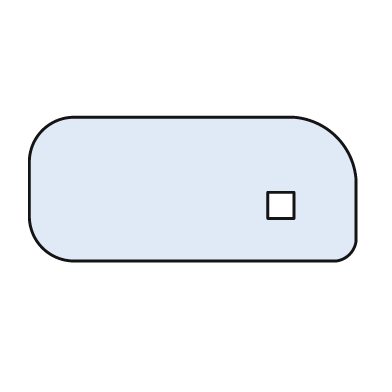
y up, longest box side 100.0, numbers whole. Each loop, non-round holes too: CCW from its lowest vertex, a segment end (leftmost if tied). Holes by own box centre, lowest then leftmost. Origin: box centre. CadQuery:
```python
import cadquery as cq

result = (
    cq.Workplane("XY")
    .moveTo(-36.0, -22.0)
    .lineTo(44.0, -22.0)
    .threePointArc((48.0, -20.0), (50.0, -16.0))
    .lineTo(50.0, 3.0)
    .threePointArc((44.0, 16.0), (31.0, 22.0))
    .lineTo(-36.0, 22.0)
    .threePointArc((-46.0, 18.0), (-50.0, 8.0))
    .lineTo(-50.0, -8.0)
    .threePointArc((-46.0, -18.0), (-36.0, -22.0))
    .close()
    .moveTo(23.0, -9.0)
    .lineTo(31.0, -9.0)
    .lineTo(31.0, -1.0)
    .lineTo(23.0, -1.0)
    .close()
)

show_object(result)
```